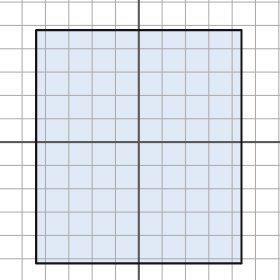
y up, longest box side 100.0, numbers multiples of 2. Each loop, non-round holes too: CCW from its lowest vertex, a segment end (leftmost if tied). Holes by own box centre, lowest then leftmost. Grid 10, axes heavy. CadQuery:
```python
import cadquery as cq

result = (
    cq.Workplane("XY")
    .moveTo(-44.0, -52.0)
    .lineTo(44.0, -52.0)
    .lineTo(44.0, 48.0)
    .lineTo(-44.0, 48.0)
    .close()
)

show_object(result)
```